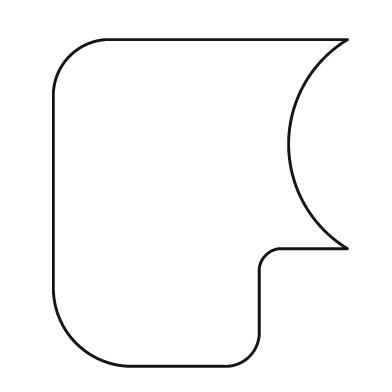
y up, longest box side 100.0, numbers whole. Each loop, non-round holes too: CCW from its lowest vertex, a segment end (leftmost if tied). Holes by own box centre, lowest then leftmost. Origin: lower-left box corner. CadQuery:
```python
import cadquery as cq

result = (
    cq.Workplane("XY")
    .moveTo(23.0, 0.0)
    .lineTo(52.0, 0.0)
    .threePointArc((60.0, 3.0), (63.0, 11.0))
    .lineTo(63.0, 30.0)
    .threePointArc((65.0, 34.0), (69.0, 36.0))
    .lineTo(90.0, 36.0)
    .threePointArc((72.0, 68.0), (90.0, 100.0))
    .lineTo(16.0, 100.0)
    .threePointArc((5.0, 95.0), (0.0, 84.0))
    .lineTo(0.0, 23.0)
    .threePointArc((7.0, 7.0), (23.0, 0.0))
    .close()
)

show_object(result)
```